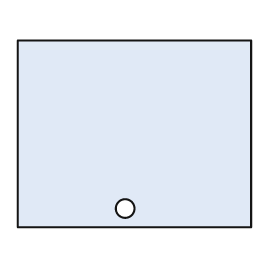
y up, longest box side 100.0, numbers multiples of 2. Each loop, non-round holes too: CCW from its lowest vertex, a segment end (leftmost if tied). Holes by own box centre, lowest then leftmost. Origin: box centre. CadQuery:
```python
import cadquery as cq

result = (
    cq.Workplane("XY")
    .moveTo(-50.0, -40.0)
    .lineTo(50.0, -40.0)
    .lineTo(50.0, 40.0)
    .lineTo(-50.0, 40.0)
    .close()
    .moveTo(-4.0, -32.0)
    .circle(4.0)
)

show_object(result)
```